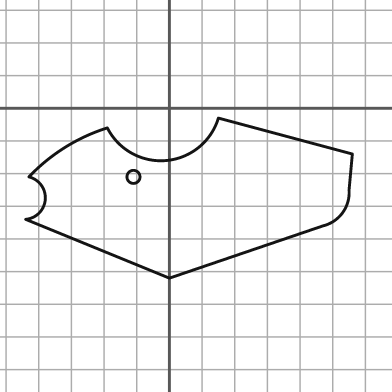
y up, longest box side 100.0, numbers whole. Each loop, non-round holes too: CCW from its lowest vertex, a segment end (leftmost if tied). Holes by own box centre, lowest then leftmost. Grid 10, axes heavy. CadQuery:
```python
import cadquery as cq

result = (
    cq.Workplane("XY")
    .moveTo(0.0, -52.0)
    .lineTo(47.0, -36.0)
    .threePointArc((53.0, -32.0), (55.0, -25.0))
    .lineTo(56.0, -14.0)
    .lineTo(15.0, -3.0)
    .threePointArc((-1.0, -16.0), (-19.0, -6.0))
    .threePointArc((-32.0, -12.0), (-43.0, -21.0))
    .threePointArc((-38.0, -28.0), (-44.0, -34.0))
    .close()
    .moveTo(-11.0, -21.0)
    .circle(2.0)
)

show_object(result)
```